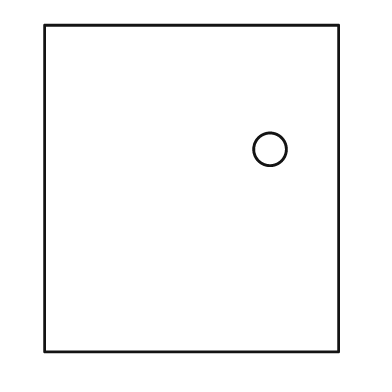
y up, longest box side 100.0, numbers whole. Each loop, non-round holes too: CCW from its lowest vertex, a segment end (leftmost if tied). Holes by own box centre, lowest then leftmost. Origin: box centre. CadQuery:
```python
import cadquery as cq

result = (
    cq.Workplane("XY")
    .moveTo(-45.0, -50.0)
    .lineTo(45.0, -50.0)
    .lineTo(45.0, 50.0)
    .lineTo(-45.0, 50.0)
    .close()
    .moveTo(24.0, 12.0)
    .circle(5.0)
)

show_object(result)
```